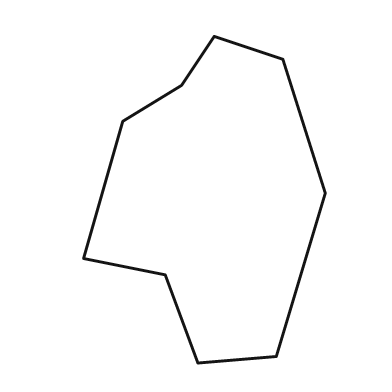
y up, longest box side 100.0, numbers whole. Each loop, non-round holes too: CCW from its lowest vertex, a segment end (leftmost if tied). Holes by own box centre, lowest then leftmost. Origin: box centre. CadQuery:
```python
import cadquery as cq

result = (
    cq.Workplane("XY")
    .moveTo(-2.0, -50.0)
    .lineTo(22.0, -48.0)
    .lineTo(37.0, 2.0)
    .lineTo(24.0, 43.0)
    .lineTo(3.0, 50.0)
    .lineTo(-7.0, 35.0)
    .lineTo(-25.0, 24.0)
    .lineTo(-37.0, -18.0)
    .lineTo(-12.0, -23.0)
    .close()
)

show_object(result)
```